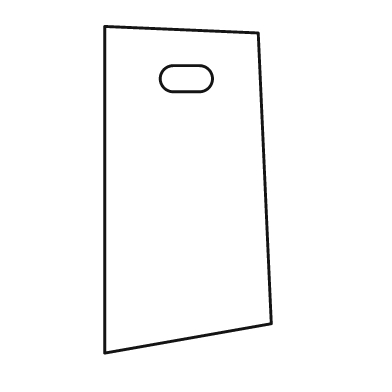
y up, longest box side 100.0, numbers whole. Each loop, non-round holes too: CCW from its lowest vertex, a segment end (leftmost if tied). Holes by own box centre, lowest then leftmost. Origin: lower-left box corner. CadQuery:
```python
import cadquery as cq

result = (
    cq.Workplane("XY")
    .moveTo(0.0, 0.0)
    .lineTo(51.0, 9.0)
    .lineTo(47.0, 98.0)
    .lineTo(0.0, 100.0)
    .close()
    .moveTo(21.0, 80.0)
    .lineTo(29.0, 80.0)
    .threePointArc((33.0, 84.0), (29.0, 88.0))
    .lineTo(21.0, 88.0)
    .threePointArc((17.0, 84.0), (21.0, 80.0))
    .close()
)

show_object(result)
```